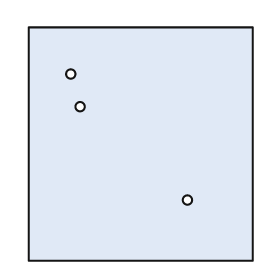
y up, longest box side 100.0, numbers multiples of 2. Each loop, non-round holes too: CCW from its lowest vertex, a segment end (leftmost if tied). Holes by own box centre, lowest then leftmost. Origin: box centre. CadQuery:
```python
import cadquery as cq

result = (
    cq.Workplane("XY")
    .moveTo(-48.0, -50.0)
    .lineTo(48.0, -50.0)
    .lineTo(48.0, 50.0)
    .lineTo(-48.0, 50.0)
    .close()
    .moveTo(20.0, -24.0)
    .circle(2.0)
    .moveTo(-26.0, 16.0)
    .circle(2.0)
    .moveTo(-30.0, 30.0)
    .circle(2.0)
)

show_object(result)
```